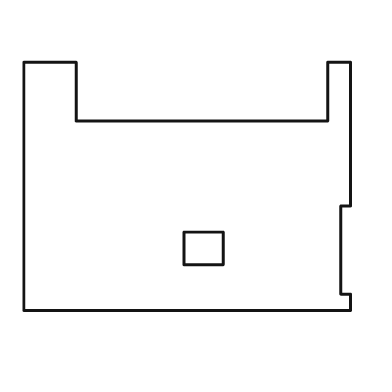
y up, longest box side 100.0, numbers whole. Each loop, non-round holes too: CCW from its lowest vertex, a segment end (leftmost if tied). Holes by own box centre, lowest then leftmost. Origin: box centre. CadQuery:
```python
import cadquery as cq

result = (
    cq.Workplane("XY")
    .moveTo(-50.0, -38.0)
    .lineTo(50.0, -38.0)
    .lineTo(50.0, -33.0)
    .lineTo(47.0, -33.0)
    .lineTo(47.0, -6.0)
    .lineTo(50.0, -6.0)
    .lineTo(50.0, 38.0)
    .lineTo(43.0, 38.0)
    .lineTo(43.0, 20.0)
    .lineTo(-34.0, 20.0)
    .lineTo(-34.0, 38.0)
    .lineTo(-50.0, 38.0)
    .close()
    .moveTo(-1.0, -24.0)
    .lineTo(11.0, -24.0)
    .lineTo(11.0, -14.0)
    .lineTo(-1.0, -14.0)
    .close()
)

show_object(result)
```